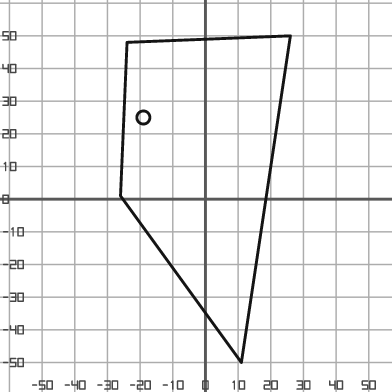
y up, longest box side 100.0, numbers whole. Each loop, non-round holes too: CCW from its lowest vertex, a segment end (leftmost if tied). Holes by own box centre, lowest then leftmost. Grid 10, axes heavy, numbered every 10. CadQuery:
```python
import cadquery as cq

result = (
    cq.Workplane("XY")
    .moveTo(11.0, -50.0)
    .lineTo(26.0, 50.0)
    .lineTo(-24.0, 48.0)
    .lineTo(-26.0, 1.0)
    .close()
    .moveTo(-19.0, 25.0)
    .circle(2.0)
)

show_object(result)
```